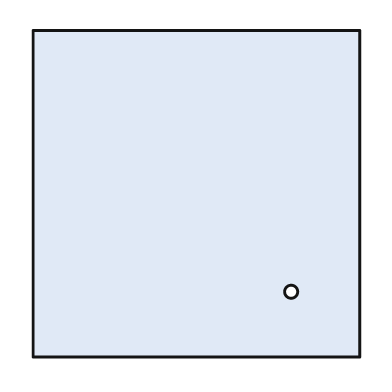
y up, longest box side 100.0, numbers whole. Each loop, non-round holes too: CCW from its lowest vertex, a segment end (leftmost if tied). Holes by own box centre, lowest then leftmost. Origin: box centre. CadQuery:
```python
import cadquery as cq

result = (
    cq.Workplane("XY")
    .moveTo(-50.0, -50.0)
    .lineTo(50.0, -50.0)
    .lineTo(50.0, 50.0)
    .lineTo(-50.0, 50.0)
    .close()
    .moveTo(29.0, -30.0)
    .circle(2.0)
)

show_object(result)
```